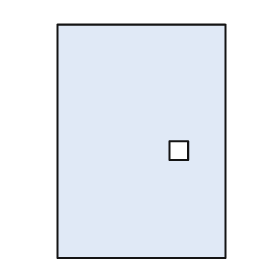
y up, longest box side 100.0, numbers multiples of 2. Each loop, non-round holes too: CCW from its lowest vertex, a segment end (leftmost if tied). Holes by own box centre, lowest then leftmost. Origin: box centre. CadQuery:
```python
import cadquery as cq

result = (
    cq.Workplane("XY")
    .moveTo(-36.0, -50.0)
    .lineTo(36.0, -50.0)
    .lineTo(36.0, 50.0)
    .lineTo(-36.0, 50.0)
    .close()
    .moveTo(12.0, -8.0)
    .lineTo(20.0, -8.0)
    .lineTo(20.0, 0.0)
    .lineTo(12.0, 0.0)
    .close()
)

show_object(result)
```